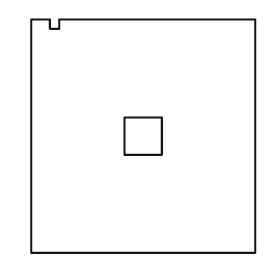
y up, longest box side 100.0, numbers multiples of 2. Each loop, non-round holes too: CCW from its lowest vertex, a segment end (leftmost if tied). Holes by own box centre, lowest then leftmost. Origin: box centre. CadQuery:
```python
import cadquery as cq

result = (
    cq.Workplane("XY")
    .moveTo(-48.0, -50.0)
    .lineTo(48.0, -50.0)
    .lineTo(48.0, 50.0)
    .lineTo(-36.0, 50.0)
    .lineTo(-36.0, 46.0)
    .lineTo(-40.0, 46.0)
    .lineTo(-40.0, 50.0)
    .lineTo(-48.0, 50.0)
    .close()
    .moveTo(-8.0, -8.0)
    .lineTo(8.0, -8.0)
    .lineTo(8.0, 8.0)
    .lineTo(-8.0, 8.0)
    .close()
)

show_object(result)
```